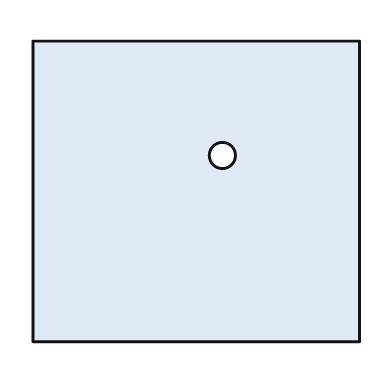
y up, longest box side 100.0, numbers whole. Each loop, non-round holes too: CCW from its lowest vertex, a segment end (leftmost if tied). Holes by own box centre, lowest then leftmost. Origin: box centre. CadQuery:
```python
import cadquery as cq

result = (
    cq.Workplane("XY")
    .moveTo(-50.0, -46.0)
    .lineTo(50.0, -46.0)
    .lineTo(50.0, 46.0)
    .lineTo(-50.0, 46.0)
    .close()
    .moveTo(8.0, 11.0)
    .circle(4.0)
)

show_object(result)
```